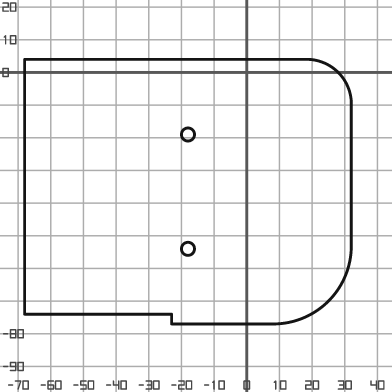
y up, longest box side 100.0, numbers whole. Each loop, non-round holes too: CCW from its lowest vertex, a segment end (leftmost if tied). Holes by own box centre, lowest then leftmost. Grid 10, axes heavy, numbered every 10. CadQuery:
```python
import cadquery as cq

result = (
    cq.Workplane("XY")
    .moveTo(-23.0, -77.0)
    .lineTo(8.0, -77.0)
    .threePointArc((25.0, -70.0), (32.0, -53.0))
    .lineTo(32.0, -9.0)
    .threePointArc((28.0, 0.0), (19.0, 4.0))
    .lineTo(-68.0, 4.0)
    .lineTo(-68.0, -74.0)
    .lineTo(-23.0, -74.0)
    .close()
    .moveTo(-18.0, -54.0)
    .circle(2.0)
    .moveTo(-18.0, -19.0)
    .circle(2.0)
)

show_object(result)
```